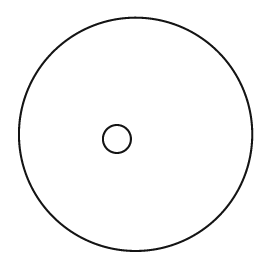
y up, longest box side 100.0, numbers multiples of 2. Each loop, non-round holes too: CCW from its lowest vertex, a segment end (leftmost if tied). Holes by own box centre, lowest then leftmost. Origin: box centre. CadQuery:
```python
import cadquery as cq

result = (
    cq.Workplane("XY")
    .moveTo(0.0, 0.0)
    .circle(50.0)
    .moveTo(-8.0, -2.0)
    .circle(6.0)
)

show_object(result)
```